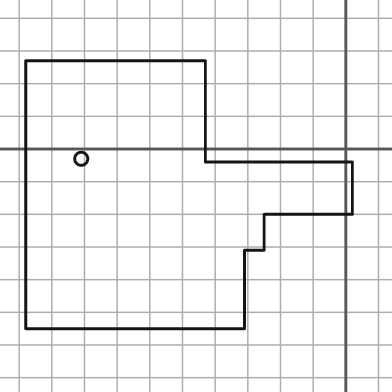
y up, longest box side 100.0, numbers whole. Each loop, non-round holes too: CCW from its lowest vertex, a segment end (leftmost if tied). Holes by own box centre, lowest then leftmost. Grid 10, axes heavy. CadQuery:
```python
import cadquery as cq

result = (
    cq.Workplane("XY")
    .moveTo(-98.0, -55.0)
    .lineTo(-31.0, -55.0)
    .lineTo(-31.0, -31.0)
    .lineTo(-25.0, -31.0)
    .lineTo(-25.0, -20.0)
    .lineTo(2.0, -20.0)
    .lineTo(2.0, -4.0)
    .lineTo(-43.0, -4.0)
    .lineTo(-43.0, 27.0)
    .lineTo(-98.0, 27.0)
    .close()
    .moveTo(-81.0, -3.0)
    .circle(2.0)
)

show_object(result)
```